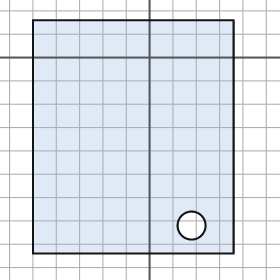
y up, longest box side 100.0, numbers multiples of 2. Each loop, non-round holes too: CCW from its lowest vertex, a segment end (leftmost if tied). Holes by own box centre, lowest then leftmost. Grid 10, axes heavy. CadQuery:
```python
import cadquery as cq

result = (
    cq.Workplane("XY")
    .moveTo(-50.0, -84.0)
    .lineTo(36.0, -84.0)
    .lineTo(36.0, 16.0)
    .lineTo(-50.0, 16.0)
    .close()
    .moveTo(18.0, -72.0)
    .circle(6.0)
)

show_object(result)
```